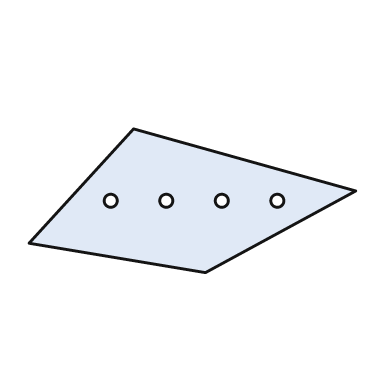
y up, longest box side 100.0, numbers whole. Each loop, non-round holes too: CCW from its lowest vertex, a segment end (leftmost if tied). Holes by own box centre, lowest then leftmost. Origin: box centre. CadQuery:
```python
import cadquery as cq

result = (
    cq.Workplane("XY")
    .moveTo(4.0, -22.0)
    .lineTo(50.0, 3.0)
    .lineTo(-18.0, 22.0)
    .lineTo(-50.0, -13.0)
    .close()
    .moveTo(-25.0, 0.0)
    .circle(2.0)
    .moveTo(-8.0, 0.0)
    .circle(2.0)
    .moveTo(9.0, 0.0)
    .circle(2.0)
    .moveTo(26.0, 0.0)
    .circle(2.0)
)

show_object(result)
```